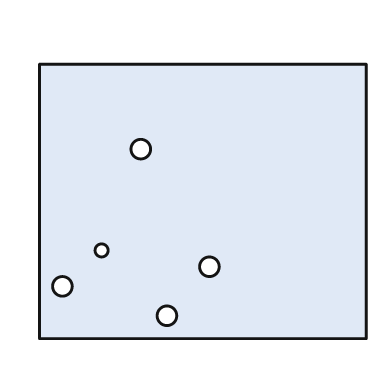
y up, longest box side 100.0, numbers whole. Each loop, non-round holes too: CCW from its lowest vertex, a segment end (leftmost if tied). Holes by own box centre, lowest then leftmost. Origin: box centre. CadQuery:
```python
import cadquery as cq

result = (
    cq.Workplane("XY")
    .moveTo(-50.0, -42.0)
    .lineTo(50.0, -42.0)
    .lineTo(50.0, 42.0)
    .lineTo(-50.0, 42.0)
    .close()
    .moveTo(-11.0, -35.0)
    .circle(3.0)
    .moveTo(-43.0, -26.0)
    .circle(3.0)
    .moveTo(2.0, -20.0)
    .circle(3.0)
    .moveTo(-31.0, -15.0)
    .circle(2.0)
    .moveTo(-19.0, 16.0)
    .circle(3.0)
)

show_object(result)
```